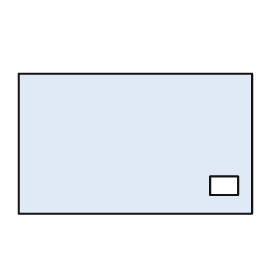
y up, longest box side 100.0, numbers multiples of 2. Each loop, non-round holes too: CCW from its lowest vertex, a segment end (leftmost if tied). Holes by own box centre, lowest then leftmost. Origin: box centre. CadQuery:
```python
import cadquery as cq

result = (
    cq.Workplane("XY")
    .moveTo(-50.0, -30.0)
    .lineTo(50.0, -30.0)
    .lineTo(50.0, 30.0)
    .lineTo(-50.0, 30.0)
    .close()
    .moveTo(32.0, -22.0)
    .lineTo(44.0, -22.0)
    .lineTo(44.0, -14.0)
    .lineTo(32.0, -14.0)
    .close()
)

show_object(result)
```